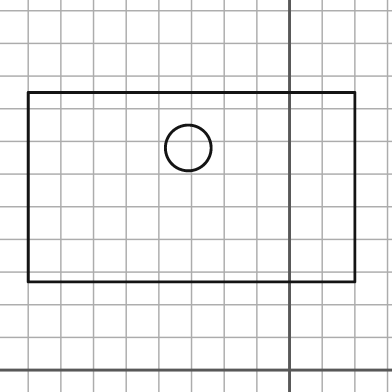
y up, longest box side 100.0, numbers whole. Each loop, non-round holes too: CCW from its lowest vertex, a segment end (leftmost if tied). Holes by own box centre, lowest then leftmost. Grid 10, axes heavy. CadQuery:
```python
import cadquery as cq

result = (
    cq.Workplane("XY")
    .moveTo(-80.0, 27.0)
    .lineTo(20.0, 27.0)
    .lineTo(20.0, 85.0)
    .lineTo(-80.0, 85.0)
    .close()
    .moveTo(-31.0, 68.0)
    .circle(7.0)
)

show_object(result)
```